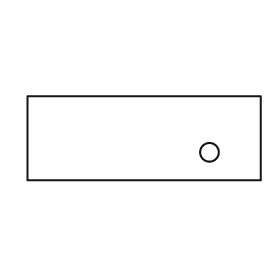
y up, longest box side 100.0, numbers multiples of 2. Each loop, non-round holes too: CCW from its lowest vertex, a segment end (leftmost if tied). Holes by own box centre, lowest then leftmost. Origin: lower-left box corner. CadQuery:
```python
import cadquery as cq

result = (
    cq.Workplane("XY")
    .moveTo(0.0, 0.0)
    .lineTo(100.0, 0.0)
    .lineTo(100.0, 36.0)
    .lineTo(0.0, 36.0)
    .close()
    .moveTo(78.0, 12.0)
    .circle(4.0)
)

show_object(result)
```